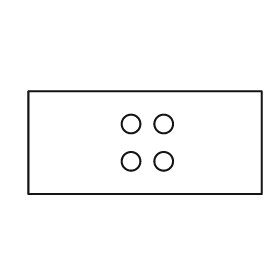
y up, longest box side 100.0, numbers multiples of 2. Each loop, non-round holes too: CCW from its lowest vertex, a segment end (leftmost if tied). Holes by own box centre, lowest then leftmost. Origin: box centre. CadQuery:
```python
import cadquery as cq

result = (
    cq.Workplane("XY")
    .moveTo(-50.0, -22.0)
    .lineTo(50.0, -22.0)
    .lineTo(50.0, 22.0)
    .lineTo(-50.0, 22.0)
    .close()
    .moveTo(-6.0, -8.0)
    .circle(4.0)
    .moveTo(8.0, -8.0)
    .circle(4.0)
    .moveTo(-6.0, 8.0)
    .circle(4.0)
    .moveTo(8.0, 8.0)
    .circle(4.0)
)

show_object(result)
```